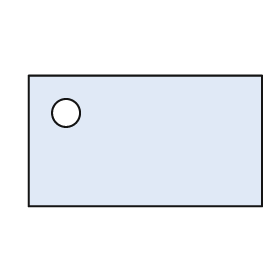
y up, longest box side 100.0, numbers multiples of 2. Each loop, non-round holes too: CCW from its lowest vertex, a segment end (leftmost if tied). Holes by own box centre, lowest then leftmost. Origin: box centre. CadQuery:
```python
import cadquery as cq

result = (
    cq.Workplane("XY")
    .moveTo(-50.0, -28.0)
    .lineTo(50.0, -28.0)
    .lineTo(50.0, 28.0)
    .lineTo(-50.0, 28.0)
    .close()
    .moveTo(-34.0, 12.0)
    .circle(6.0)
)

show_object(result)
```